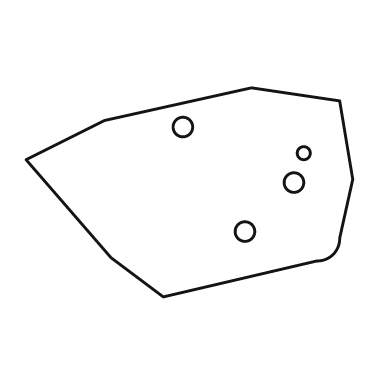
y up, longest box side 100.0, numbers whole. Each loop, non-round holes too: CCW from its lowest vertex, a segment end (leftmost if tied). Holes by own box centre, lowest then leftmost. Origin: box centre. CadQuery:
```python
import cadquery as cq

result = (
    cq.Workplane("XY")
    .moveTo(-8.0, -32.0)
    .lineTo(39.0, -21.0)
    .threePointArc((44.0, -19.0), (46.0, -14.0))
    .lineTo(50.0, 4.0)
    .lineTo(46.0, 28.0)
    .lineTo(19.0, 32.0)
    .lineTo(-26.0, 22.0)
    .lineTo(-50.0, 10.0)
    .lineTo(-24.0, -20.0)
    .close()
    .moveTo(17.0, -12.0)
    .circle(3.0)
    .moveTo(32.0, 3.0)
    .circle(3.0)
    .moveTo(35.0, 12.0)
    .circle(2.0)
    .moveTo(-2.0, 20.0)
    .circle(3.0)
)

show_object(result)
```